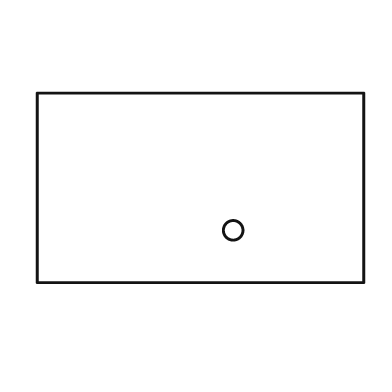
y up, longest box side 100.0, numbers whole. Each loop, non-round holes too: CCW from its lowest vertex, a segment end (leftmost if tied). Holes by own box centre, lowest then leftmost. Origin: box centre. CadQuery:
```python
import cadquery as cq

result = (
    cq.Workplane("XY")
    .moveTo(-50.0, -29.0)
    .lineTo(50.0, -29.0)
    .lineTo(50.0, 29.0)
    .lineTo(-50.0, 29.0)
    .close()
    .moveTo(10.0, -13.0)
    .circle(3.0)
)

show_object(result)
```